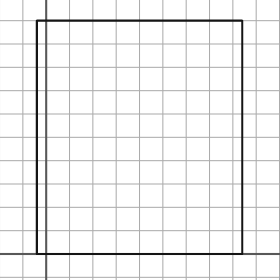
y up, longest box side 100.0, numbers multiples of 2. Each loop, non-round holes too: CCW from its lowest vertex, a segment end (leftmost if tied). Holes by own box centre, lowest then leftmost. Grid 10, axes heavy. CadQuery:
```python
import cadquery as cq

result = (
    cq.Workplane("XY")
    .moveTo(-4.0, 0.0)
    .lineTo(84.0, 0.0)
    .lineTo(84.0, 100.0)
    .lineTo(-4.0, 100.0)
    .close()
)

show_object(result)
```